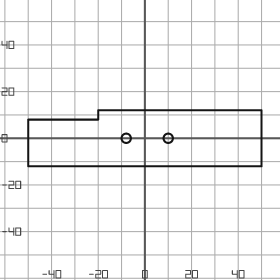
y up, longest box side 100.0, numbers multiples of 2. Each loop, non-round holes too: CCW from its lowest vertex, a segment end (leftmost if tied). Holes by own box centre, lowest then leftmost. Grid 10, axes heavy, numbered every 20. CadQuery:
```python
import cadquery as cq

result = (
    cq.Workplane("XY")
    .moveTo(-50.0, -12.0)
    .lineTo(50.0, -12.0)
    .lineTo(50.0, 12.0)
    .lineTo(-20.0, 12.0)
    .lineTo(-20.0, 8.0)
    .lineTo(-50.0, 8.0)
    .close()
    .moveTo(-8.0, 0.0)
    .circle(2.0)
    .moveTo(10.0, 0.0)
    .circle(2.0)
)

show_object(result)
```